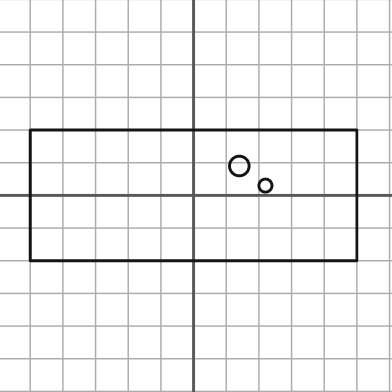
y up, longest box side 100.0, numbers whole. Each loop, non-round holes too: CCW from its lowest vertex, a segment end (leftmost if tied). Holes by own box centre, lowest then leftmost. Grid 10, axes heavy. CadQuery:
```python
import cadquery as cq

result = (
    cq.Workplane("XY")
    .moveTo(-50.0, -20.0)
    .lineTo(50.0, -20.0)
    .lineTo(50.0, 20.0)
    .lineTo(-50.0, 20.0)
    .close()
    .moveTo(22.0, 3.0)
    .circle(2.0)
    .moveTo(14.0, 9.0)
    .circle(3.0)
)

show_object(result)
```